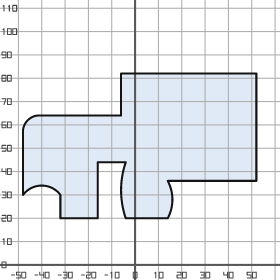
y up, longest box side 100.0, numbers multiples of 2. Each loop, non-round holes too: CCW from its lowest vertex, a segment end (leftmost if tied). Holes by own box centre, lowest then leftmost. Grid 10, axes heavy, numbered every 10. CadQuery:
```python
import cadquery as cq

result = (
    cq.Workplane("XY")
    .moveTo(-32.0, 20.0)
    .lineTo(-16.0, 20.0)
    .lineTo(-16.0, 44.0)
    .lineTo(-4.0, 44.0)
    .threePointArc((-6.0, 32.0), (-4.0, 20.0))
    .lineTo(14.0, 20.0)
    .threePointArc((16.0, 28.0), (14.0, 36.0))
    .lineTo(52.0, 36.0)
    .lineTo(52.0, 82.0)
    .lineTo(-6.0, 82.0)
    .lineTo(-6.0, 64.0)
    .lineTo(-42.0, 64.0)
    .threePointArc((-46.0, 62.0), (-48.0, 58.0))
    .lineTo(-48.0, 30.0)
    .threePointArc((-40.0, 34.0), (-32.0, 30.0))
    .close()
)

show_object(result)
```